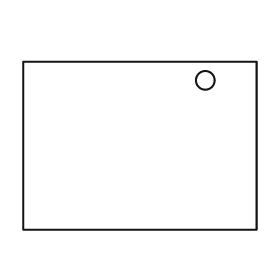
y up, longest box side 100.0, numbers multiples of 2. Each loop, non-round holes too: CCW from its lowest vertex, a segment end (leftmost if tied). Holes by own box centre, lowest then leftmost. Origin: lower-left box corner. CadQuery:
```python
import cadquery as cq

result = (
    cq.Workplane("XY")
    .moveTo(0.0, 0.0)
    .lineTo(100.0, 0.0)
    .lineTo(100.0, 72.0)
    .lineTo(0.0, 72.0)
    .close()
    .moveTo(78.0, 64.0)
    .circle(4.0)
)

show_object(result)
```